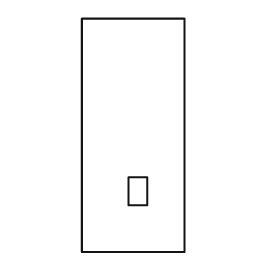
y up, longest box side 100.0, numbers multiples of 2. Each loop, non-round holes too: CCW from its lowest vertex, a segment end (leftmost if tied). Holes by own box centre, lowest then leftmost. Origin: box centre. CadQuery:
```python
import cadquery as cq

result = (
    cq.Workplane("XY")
    .moveTo(-22.0, -50.0)
    .lineTo(22.0, -50.0)
    .lineTo(22.0, 50.0)
    .lineTo(-22.0, 50.0)
    .close()
    .moveTo(-2.0, -30.0)
    .lineTo(6.0, -30.0)
    .lineTo(6.0, -18.0)
    .lineTo(-2.0, -18.0)
    .close()
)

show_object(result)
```